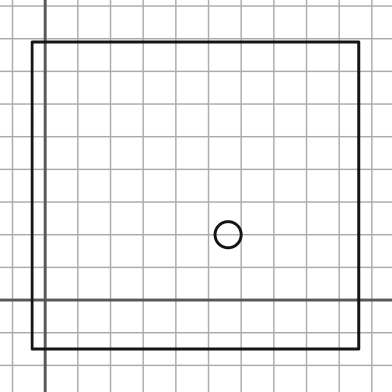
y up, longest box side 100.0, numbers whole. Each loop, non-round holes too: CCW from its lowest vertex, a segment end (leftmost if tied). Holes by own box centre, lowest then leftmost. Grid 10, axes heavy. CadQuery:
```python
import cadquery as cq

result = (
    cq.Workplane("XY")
    .moveTo(-4.0, -15.0)
    .lineTo(96.0, -15.0)
    .lineTo(96.0, 79.0)
    .lineTo(-4.0, 79.0)
    .close()
    .moveTo(56.0, 20.0)
    .circle(4.0)
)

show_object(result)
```